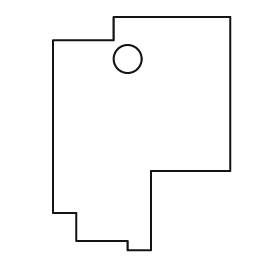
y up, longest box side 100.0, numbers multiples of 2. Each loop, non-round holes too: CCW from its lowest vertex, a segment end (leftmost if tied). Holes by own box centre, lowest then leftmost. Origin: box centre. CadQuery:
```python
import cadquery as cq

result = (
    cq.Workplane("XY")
    .moveTo(-6.0, -50.0)
    .lineTo(4.0, -50.0)
    .lineTo(4.0, -16.0)
    .lineTo(38.0, -16.0)
    .lineTo(38.0, 50.0)
    .lineTo(-12.0, 50.0)
    .lineTo(-12.0, 40.0)
    .lineTo(-38.0, 40.0)
    .lineTo(-38.0, -34.0)
    .lineTo(-28.0, -34.0)
    .lineTo(-28.0, -46.0)
    .lineTo(-6.0, -46.0)
    .close()
    .moveTo(-6.0, 32.0)
    .circle(6.0)
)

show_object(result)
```